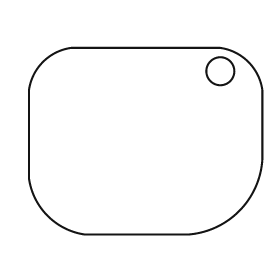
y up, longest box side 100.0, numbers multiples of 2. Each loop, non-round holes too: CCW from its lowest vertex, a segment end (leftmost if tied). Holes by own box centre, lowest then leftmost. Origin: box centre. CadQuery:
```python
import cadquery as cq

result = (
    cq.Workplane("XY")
    .moveTo(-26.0, -40.0)
    .lineTo(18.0, -40.0)
    .threePointArc((40.0, -30.0), (50.0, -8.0))
    .lineTo(50.0, 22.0)
    .threePointArc((44.0, 34.0), (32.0, 40.0))
    .lineTo(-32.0, 40.0)
    .threePointArc((-44.0, 34.0), (-50.0, 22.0))
    .lineTo(-50.0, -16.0)
    .threePointArc((-42.0, -32.0), (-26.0, -40.0))
    .close()
    .moveTo(32.0, 30.0)
    .circle(6.0)
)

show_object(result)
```